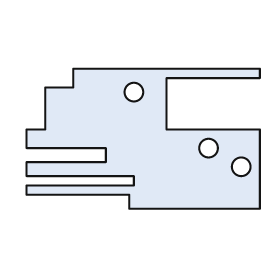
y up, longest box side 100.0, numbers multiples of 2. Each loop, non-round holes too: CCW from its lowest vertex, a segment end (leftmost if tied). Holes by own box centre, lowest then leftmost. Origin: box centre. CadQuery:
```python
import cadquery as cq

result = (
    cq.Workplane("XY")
    .moveTo(-6.0, -30.0)
    .lineTo(50.0, -30.0)
    .lineTo(50.0, 4.0)
    .lineTo(10.0, 4.0)
    .lineTo(10.0, 26.0)
    .lineTo(50.0, 26.0)
    .lineTo(50.0, 30.0)
    .lineTo(-30.0, 30.0)
    .lineTo(-30.0, 22.0)
    .lineTo(-42.0, 22.0)
    .lineTo(-42.0, 4.0)
    .lineTo(-50.0, 4.0)
    .lineTo(-50.0, -4.0)
    .lineTo(-16.0, -4.0)
    .lineTo(-16.0, -10.0)
    .lineTo(-50.0, -10.0)
    .lineTo(-50.0, -16.0)
    .lineTo(-4.0, -16.0)
    .lineTo(-4.0, -20.0)
    .lineTo(-50.0, -20.0)
    .lineTo(-50.0, -24.0)
    .lineTo(-6.0, -24.0)
    .close()
    .moveTo(42.0, -12.0)
    .circle(4.0)
    .moveTo(28.0, -4.0)
    .circle(4.0)
    .moveTo(-4.0, 20.0)
    .circle(4.0)
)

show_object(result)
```